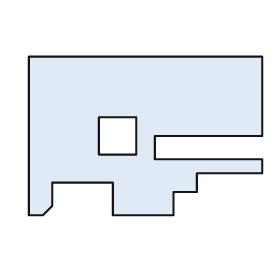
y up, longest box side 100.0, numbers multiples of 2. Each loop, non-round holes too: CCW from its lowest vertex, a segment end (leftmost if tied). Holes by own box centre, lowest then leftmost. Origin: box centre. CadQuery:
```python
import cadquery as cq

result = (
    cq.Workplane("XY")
    .moveTo(-50.0, -34.0)
    .lineTo(-44.0, -34.0)
    .lineTo(-40.0, -30.0)
    .lineTo(-40.0, -20.0)
    .lineTo(-14.0, -20.0)
    .lineTo(-14.0, -34.0)
    .lineTo(12.0, -34.0)
    .lineTo(12.0, -24.0)
    .lineTo(22.0, -24.0)
    .lineTo(22.0, -16.0)
    .lineTo(50.0, -16.0)
    .lineTo(50.0, -10.0)
    .lineTo(4.0, -10.0)
    .lineTo(4.0, 0.0)
    .lineTo(50.0, 0.0)
    .lineTo(50.0, 34.0)
    .lineTo(-50.0, 34.0)
    .close()
    .moveTo(-20.0, -8.0)
    .lineTo(-4.0, -8.0)
    .lineTo(-4.0, 8.0)
    .lineTo(-20.0, 8.0)
    .close()
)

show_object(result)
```